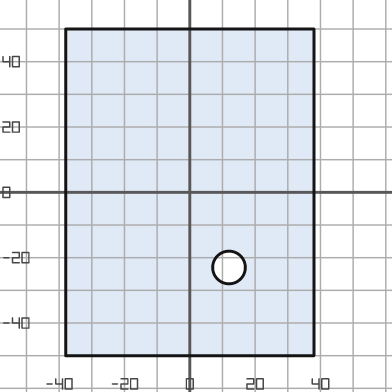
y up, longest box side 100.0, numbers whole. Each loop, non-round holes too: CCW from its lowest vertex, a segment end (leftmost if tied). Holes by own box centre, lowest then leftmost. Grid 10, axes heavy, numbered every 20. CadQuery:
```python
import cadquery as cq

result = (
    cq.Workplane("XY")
    .moveTo(-38.0, -50.0)
    .lineTo(38.0, -50.0)
    .lineTo(38.0, 50.0)
    .lineTo(-38.0, 50.0)
    .close()
    .moveTo(12.0, -23.0)
    .circle(5.0)
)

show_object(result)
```